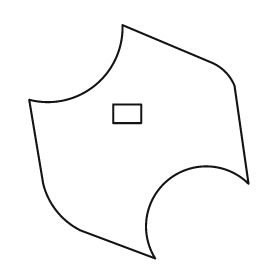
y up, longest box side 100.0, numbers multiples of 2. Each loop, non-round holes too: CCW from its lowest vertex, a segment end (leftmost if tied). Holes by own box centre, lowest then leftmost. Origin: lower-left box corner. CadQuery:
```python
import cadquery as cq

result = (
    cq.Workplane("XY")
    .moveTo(54.0, 0.0)
    .threePointArc((60.0, 34.0), (94.0, 32.0))
    .lineTo(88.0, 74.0)
    .threePointArc((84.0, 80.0), (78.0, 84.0))
    .lineTo(40.0, 100.0)
    .threePointArc((28.0, 74.0), (0.0, 68.0))
    .lineTo(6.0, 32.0)
    .threePointArc((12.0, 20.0), (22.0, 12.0))
    .close()
    .moveTo(36.0, 58.0)
    .lineTo(48.0, 58.0)
    .lineTo(48.0, 66.0)
    .lineTo(36.0, 66.0)
    .close()
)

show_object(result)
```